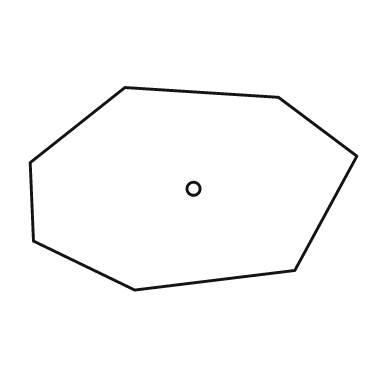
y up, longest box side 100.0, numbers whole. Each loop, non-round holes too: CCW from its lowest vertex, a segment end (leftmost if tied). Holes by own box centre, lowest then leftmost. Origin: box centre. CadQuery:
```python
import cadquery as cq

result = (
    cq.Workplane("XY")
    .moveTo(-18.0, -31.0)
    .lineTo(31.0, -25.0)
    .lineTo(50.0, 10.0)
    .lineTo(26.0, 28.0)
    .lineTo(-21.0, 31.0)
    .lineTo(-50.0, 8.0)
    .lineTo(-49.0, -16.0)
    .close()
    .moveTo(0.0, 0.0)
    .circle(2.0)
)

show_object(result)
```